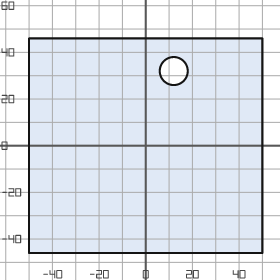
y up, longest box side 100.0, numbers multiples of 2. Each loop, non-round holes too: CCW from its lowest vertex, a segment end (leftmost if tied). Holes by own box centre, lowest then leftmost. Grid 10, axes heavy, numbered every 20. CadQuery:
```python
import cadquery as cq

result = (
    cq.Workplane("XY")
    .moveTo(-50.0, -46.0)
    .lineTo(50.0, -46.0)
    .lineTo(50.0, 46.0)
    .lineTo(-50.0, 46.0)
    .close()
    .moveTo(12.0, 32.0)
    .circle(6.0)
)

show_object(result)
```